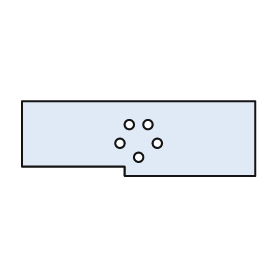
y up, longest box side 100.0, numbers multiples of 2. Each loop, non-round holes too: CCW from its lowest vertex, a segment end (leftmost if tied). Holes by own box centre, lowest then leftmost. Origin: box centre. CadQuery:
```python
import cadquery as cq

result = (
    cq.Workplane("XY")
    .moveTo(-6.0, -16.0)
    .lineTo(50.0, -16.0)
    .lineTo(50.0, 16.0)
    .lineTo(-50.0, 16.0)
    .lineTo(-50.0, -12.0)
    .lineTo(-6.0, -12.0)
    .close()
    .moveTo(0.0, -8.0)
    .circle(2.0)
    .moveTo(-8.0, -2.0)
    .circle(2.0)
    .moveTo(8.0, -2.0)
    .circle(2.0)
    .moveTo(-4.0, 6.0)
    .circle(2.0)
    .moveTo(4.0, 6.0)
    .circle(2.0)
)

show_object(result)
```